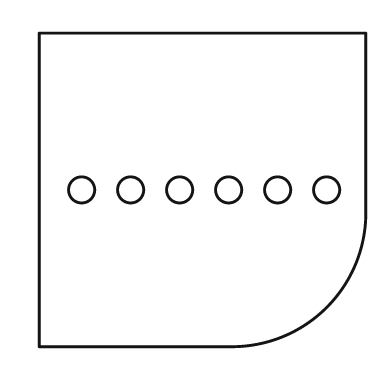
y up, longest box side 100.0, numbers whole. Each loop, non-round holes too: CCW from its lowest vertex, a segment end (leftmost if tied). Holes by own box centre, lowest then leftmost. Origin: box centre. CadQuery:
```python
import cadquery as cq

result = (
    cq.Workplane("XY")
    .moveTo(-50.0, -48.0)
    .lineTo(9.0, -48.0)
    .threePointArc((38.0, -36.0), (50.0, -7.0))
    .lineTo(50.0, 48.0)
    .lineTo(-50.0, 48.0)
    .close()
    .moveTo(-37.0, 0.0)
    .circle(4.0)
    .moveTo(-22.0, 0.0)
    .circle(4.0)
    .moveTo(-7.0, 0.0)
    .circle(4.0)
    .moveTo(8.0, 0.0)
    .circle(4.0)
    .moveTo(23.0, 0.0)
    .circle(4.0)
    .moveTo(38.0, 0.0)
    .circle(4.0)
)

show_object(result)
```